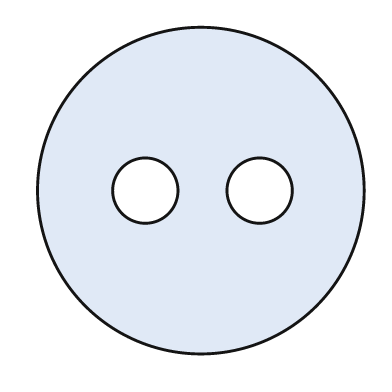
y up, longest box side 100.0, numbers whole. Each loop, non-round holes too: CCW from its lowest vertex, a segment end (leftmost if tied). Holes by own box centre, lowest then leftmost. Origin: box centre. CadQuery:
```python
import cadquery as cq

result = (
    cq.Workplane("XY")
    .moveTo(0.0, 0.0)
    .circle(50.0)
    .moveTo(-17.0, 0.0)
    .circle(10.0)
    .moveTo(18.0, 0.0)
    .circle(10.0)
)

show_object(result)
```